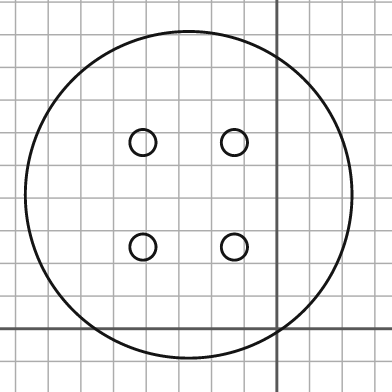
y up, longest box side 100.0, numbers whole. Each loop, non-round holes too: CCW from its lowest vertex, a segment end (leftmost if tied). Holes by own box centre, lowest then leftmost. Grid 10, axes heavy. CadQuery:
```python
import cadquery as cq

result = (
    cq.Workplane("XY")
    .moveTo(-27.0, 41.0)
    .circle(50.0)
    .moveTo(-41.0, 25.0)
    .circle(4.0)
    .moveTo(-13.0, 25.0)
    .circle(4.0)
    .moveTo(-41.0, 57.0)
    .circle(4.0)
    .moveTo(-13.0, 57.0)
    .circle(4.0)
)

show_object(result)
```